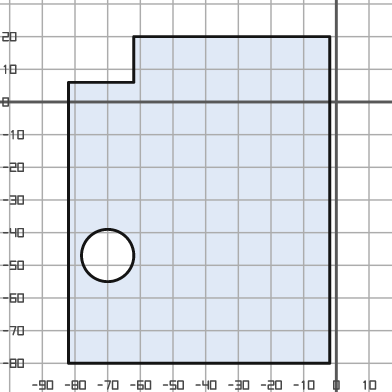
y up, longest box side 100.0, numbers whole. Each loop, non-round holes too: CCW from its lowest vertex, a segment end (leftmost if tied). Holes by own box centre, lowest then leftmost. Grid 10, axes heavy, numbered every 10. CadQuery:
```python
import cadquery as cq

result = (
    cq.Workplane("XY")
    .moveTo(-82.0, -80.0)
    .lineTo(-2.0, -80.0)
    .lineTo(-2.0, 20.0)
    .lineTo(-62.0, 20.0)
    .lineTo(-62.0, 6.0)
    .lineTo(-82.0, 6.0)
    .close()
    .moveTo(-70.0, -47.0)
    .circle(8.0)
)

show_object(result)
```